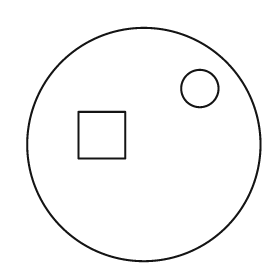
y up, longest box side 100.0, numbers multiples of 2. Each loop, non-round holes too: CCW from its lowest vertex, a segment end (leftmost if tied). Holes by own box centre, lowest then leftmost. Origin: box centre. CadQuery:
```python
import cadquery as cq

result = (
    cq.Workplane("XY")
    .moveTo(0.0, 0.0)
    .circle(50.0)
    .moveTo(-28.0, -6.0)
    .lineTo(-8.0, -6.0)
    .lineTo(-8.0, 14.0)
    .lineTo(-28.0, 14.0)
    .close()
    .moveTo(24.0, 24.0)
    .circle(8.0)
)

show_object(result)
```